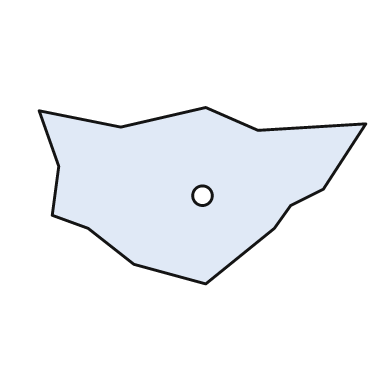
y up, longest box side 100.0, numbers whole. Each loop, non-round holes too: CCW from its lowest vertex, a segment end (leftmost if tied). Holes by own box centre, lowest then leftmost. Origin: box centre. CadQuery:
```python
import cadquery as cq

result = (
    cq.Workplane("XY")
    .moveTo(1.0, -27.0)
    .lineTo(22.0, -10.0)
    .lineTo(27.0, -3.0)
    .lineTo(37.0, 2.0)
    .lineTo(50.0, 22.0)
    .lineTo(17.0, 20.0)
    .lineTo(1.0, 27.0)
    .lineTo(-25.0, 21.0)
    .lineTo(-50.0, 26.0)
    .lineTo(-44.0, 9.0)
    .lineTo(-46.0, -6.0)
    .lineTo(-35.0, -10.0)
    .lineTo(-21.0, -21.0)
    .close()
    .moveTo(0.0, 0.0)
    .circle(3.0)
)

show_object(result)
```